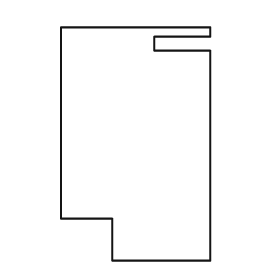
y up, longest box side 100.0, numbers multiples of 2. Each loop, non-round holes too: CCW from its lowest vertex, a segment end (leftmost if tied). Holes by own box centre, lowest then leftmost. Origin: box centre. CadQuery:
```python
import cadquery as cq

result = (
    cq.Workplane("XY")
    .moveTo(-10.0, -50.0)
    .lineTo(32.0, -50.0)
    .lineTo(32.0, 40.0)
    .lineTo(8.0, 40.0)
    .lineTo(8.0, 46.0)
    .lineTo(32.0, 46.0)
    .lineTo(32.0, 50.0)
    .lineTo(-32.0, 50.0)
    .lineTo(-32.0, -32.0)
    .lineTo(-10.0, -32.0)
    .close()
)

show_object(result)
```